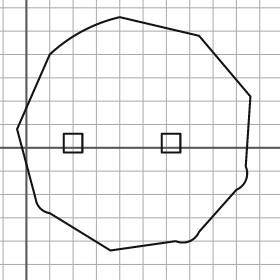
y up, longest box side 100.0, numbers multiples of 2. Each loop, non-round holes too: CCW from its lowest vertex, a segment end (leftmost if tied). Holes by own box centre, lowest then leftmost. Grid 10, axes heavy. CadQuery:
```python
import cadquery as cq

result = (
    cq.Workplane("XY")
    .moveTo(36.0, -44.0)
    .lineTo(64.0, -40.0)
    .threePointArc((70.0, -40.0), (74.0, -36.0))
    .lineTo(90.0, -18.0)
    .threePointArc((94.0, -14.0), (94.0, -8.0))
    .lineTo(96.0, 22.0)
    .lineTo(74.0, 48.0)
    .lineTo(40.0, 56.0)
    .threePointArc((24.0, 50.0), (10.0, 40.0))
    .lineTo(-4.0, 8.0)
    .lineTo(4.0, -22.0)
    .threePointArc((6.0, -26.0), (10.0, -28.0))
    .close()
    .moveTo(16.0, -2.0)
    .lineTo(24.0, -2.0)
    .lineTo(24.0, 6.0)
    .lineTo(16.0, 6.0)
    .close()
    .moveTo(58.0, -2.0)
    .lineTo(66.0, -2.0)
    .lineTo(66.0, 6.0)
    .lineTo(58.0, 6.0)
    .close()
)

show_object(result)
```